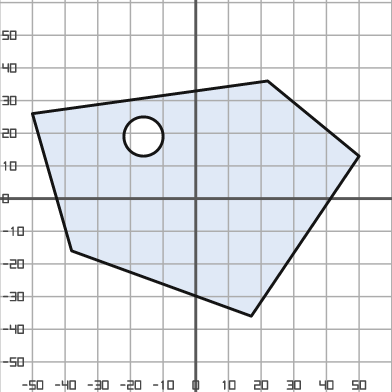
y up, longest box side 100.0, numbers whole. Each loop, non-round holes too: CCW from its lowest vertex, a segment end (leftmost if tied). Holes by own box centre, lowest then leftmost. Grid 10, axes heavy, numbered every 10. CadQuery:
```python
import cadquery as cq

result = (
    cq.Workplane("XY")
    .moveTo(17.0, -36.0)
    .lineTo(50.0, 13.0)
    .lineTo(22.0, 36.0)
    .lineTo(-50.0, 26.0)
    .lineTo(-38.0, -16.0)
    .close()
    .moveTo(-16.0, 19.0)
    .circle(6.0)
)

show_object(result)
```